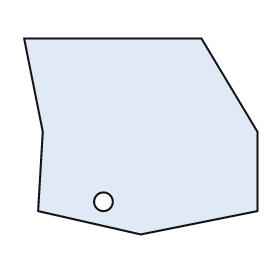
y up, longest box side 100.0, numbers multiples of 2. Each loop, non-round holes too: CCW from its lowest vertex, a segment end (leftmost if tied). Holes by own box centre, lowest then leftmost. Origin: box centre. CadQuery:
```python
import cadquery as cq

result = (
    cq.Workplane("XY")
    .moveTo(0.0, -42.0)
    .lineTo(50.0, -32.0)
    .lineTo(50.0, 2.0)
    .lineTo(26.0, 42.0)
    .lineTo(-50.0, 42.0)
    .lineTo(-42.0, 2.0)
    .lineTo(-44.0, -32.0)
    .close()
    .moveTo(-16.0, -28.0)
    .circle(4.0)
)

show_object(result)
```